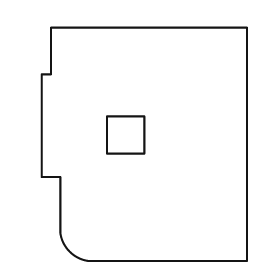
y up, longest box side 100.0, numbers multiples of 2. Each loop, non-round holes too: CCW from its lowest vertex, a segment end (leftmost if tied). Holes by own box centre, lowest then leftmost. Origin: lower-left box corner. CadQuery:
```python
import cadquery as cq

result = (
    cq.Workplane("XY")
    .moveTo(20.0, 0.0)
    .lineTo(88.0, 0.0)
    .lineTo(88.0, 100.0)
    .lineTo(4.0, 100.0)
    .lineTo(4.0, 80.0)
    .lineTo(0.0, 80.0)
    .lineTo(0.0, 36.0)
    .lineTo(8.0, 36.0)
    .lineTo(8.0, 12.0)
    .threePointArc((12.0, 4.0), (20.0, 0.0))
    .close()
    .moveTo(28.0, 46.0)
    .lineTo(44.0, 46.0)
    .lineTo(44.0, 62.0)
    .lineTo(28.0, 62.0)
    .close()
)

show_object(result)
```